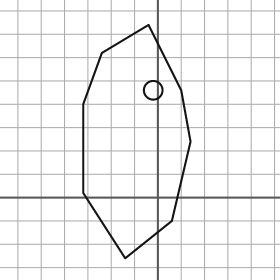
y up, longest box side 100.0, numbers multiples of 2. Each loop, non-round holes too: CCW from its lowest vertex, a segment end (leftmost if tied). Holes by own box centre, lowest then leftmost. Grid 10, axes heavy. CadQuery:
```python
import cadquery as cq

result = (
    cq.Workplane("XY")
    .moveTo(-14.0, -26.0)
    .lineTo(6.0, -10.0)
    .lineTo(14.0, 24.0)
    .lineTo(10.0, 46.0)
    .lineTo(-4.0, 74.0)
    .lineTo(-24.0, 62.0)
    .lineTo(-32.0, 40.0)
    .lineTo(-32.0, 2.0)
    .close()
    .moveTo(-2.0, 46.0)
    .circle(4.0)
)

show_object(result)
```